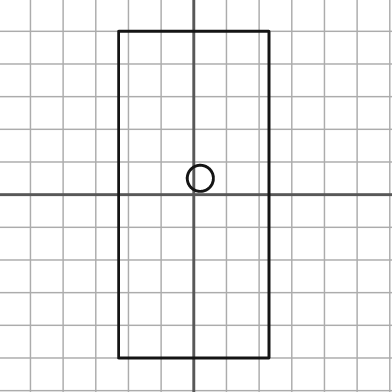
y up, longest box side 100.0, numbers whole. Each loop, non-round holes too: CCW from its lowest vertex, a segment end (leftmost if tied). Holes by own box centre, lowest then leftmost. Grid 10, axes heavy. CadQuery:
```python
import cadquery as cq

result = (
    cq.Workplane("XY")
    .moveTo(-23.0, -50.0)
    .lineTo(23.0, -50.0)
    .lineTo(23.0, 50.0)
    .lineTo(-23.0, 50.0)
    .close()
    .moveTo(2.0, 5.0)
    .circle(4.0)
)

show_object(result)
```